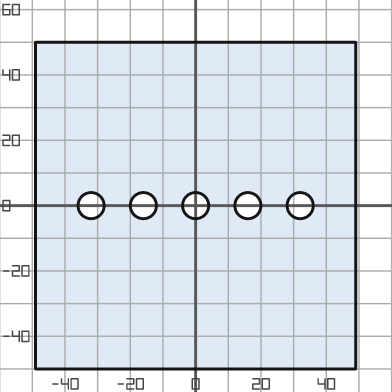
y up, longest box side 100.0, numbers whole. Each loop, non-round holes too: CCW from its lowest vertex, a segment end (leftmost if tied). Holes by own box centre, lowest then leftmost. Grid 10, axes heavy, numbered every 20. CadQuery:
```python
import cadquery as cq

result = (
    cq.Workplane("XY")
    .moveTo(-49.0, -50.0)
    .lineTo(49.0, -50.0)
    .lineTo(49.0, 50.0)
    .lineTo(-49.0, 50.0)
    .close()
    .moveTo(-32.0, 0.0)
    .circle(4.0)
    .moveTo(-16.0, 0.0)
    .circle(4.0)
    .moveTo(0.0, 0.0)
    .circle(4.0)
    .moveTo(16.0, 0.0)
    .circle(4.0)
    .moveTo(32.0, 0.0)
    .circle(4.0)
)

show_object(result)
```